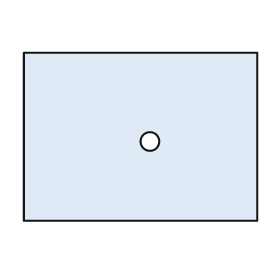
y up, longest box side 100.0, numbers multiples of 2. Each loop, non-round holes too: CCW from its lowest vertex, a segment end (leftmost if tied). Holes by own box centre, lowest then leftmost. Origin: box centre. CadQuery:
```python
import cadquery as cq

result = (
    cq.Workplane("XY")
    .moveTo(-50.0, -36.0)
    .lineTo(50.0, -36.0)
    .lineTo(50.0, 36.0)
    .lineTo(-50.0, 36.0)
    .close()
    .moveTo(4.0, -2.0)
    .circle(4.0)
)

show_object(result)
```